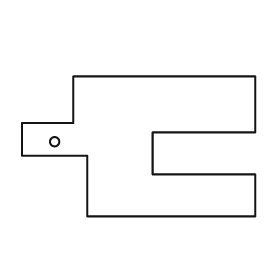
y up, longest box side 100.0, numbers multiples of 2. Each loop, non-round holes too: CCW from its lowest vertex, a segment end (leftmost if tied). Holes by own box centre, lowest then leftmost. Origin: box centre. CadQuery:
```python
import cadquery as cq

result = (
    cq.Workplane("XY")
    .moveTo(-22.0, -30.0)
    .lineTo(50.0, -30.0)
    .lineTo(50.0, -12.0)
    .lineTo(6.0, -12.0)
    .lineTo(6.0, 6.0)
    .lineTo(50.0, 6.0)
    .lineTo(50.0, 30.0)
    .lineTo(-28.0, 30.0)
    .lineTo(-28.0, 10.0)
    .lineTo(-50.0, 10.0)
    .lineTo(-50.0, -4.0)
    .lineTo(-22.0, -4.0)
    .close()
    .moveTo(-36.0, 2.0)
    .circle(2.0)
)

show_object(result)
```